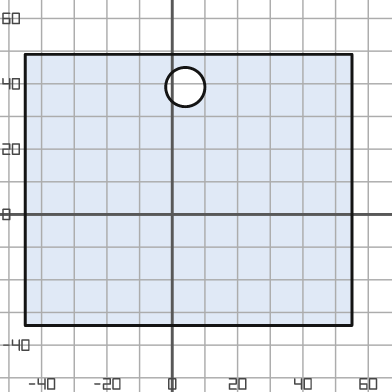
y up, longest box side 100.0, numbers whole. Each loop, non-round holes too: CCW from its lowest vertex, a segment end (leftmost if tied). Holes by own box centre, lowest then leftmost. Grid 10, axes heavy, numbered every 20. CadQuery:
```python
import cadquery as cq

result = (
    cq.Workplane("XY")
    .moveTo(-45.0, -34.0)
    .lineTo(55.0, -34.0)
    .lineTo(55.0, 49.0)
    .lineTo(-45.0, 49.0)
    .close()
    .moveTo(4.0, 39.0)
    .circle(6.0)
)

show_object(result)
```